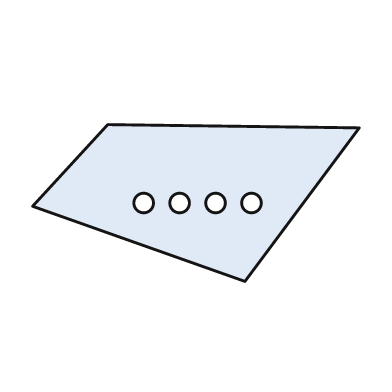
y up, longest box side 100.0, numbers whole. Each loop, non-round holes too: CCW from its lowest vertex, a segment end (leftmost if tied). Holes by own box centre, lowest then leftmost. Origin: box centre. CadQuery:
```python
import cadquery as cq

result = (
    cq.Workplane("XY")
    .moveTo(15.0, -24.0)
    .lineTo(50.0, 23.0)
    .lineTo(-27.0, 24.0)
    .lineTo(-50.0, -1.0)
    .close()
    .moveTo(-16.0, 0.0)
    .circle(3.0)
    .moveTo(-5.0, 0.0)
    .circle(3.0)
    .moveTo(6.0, 0.0)
    .circle(3.0)
    .moveTo(17.0, 0.0)
    .circle(3.0)
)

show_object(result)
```